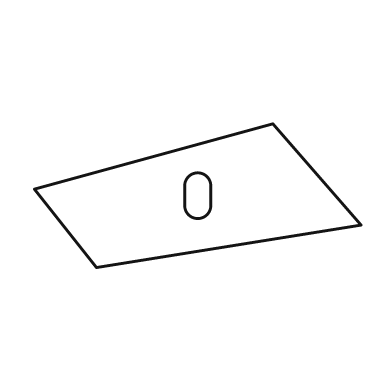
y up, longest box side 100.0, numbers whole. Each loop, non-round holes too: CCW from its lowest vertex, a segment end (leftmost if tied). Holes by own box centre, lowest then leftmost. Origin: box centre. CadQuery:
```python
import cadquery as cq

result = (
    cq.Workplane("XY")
    .moveTo(-31.0, -22.0)
    .lineTo(50.0, -9.0)
    .lineTo(23.0, 22.0)
    .lineTo(-50.0, 2.0)
    .close()
    .moveTo(-4.0, -3.0)
    .threePointArc((0.0, -7.0), (4.0, -3.0))
    .lineTo(4.0, 3.0)
    .threePointArc((0.0, 7.0), (-4.0, 3.0))
    .close()
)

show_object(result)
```